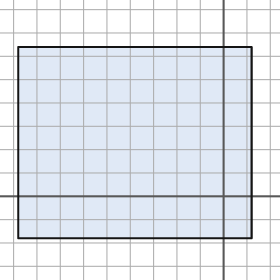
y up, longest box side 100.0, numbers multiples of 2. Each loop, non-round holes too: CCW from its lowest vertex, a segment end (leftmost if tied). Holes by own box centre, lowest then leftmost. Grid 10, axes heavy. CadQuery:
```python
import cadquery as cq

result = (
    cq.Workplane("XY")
    .moveTo(-88.0, -18.0)
    .lineTo(12.0, -18.0)
    .lineTo(12.0, 64.0)
    .lineTo(-88.0, 64.0)
    .close()
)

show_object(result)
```